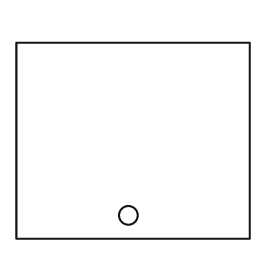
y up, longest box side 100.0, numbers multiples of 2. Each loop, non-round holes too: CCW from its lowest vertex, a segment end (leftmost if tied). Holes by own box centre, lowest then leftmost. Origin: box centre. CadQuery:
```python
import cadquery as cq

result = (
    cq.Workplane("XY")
    .moveTo(-50.0, -42.0)
    .lineTo(50.0, -42.0)
    .lineTo(50.0, 42.0)
    .lineTo(-50.0, 42.0)
    .close()
    .moveTo(-2.0, -32.0)
    .circle(4.0)
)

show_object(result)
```